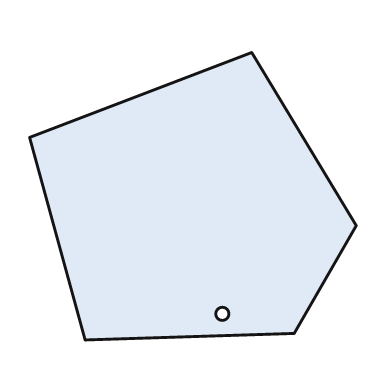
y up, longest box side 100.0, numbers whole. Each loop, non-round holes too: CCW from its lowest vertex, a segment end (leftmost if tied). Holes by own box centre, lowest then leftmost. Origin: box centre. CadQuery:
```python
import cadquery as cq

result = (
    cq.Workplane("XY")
    .moveTo(-33.0, -44.0)
    .lineTo(31.0, -42.0)
    .lineTo(50.0, -9.0)
    .lineTo(18.0, 44.0)
    .lineTo(-50.0, 18.0)
    .close()
    .moveTo(9.0, -36.0)
    .circle(2.0)
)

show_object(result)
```